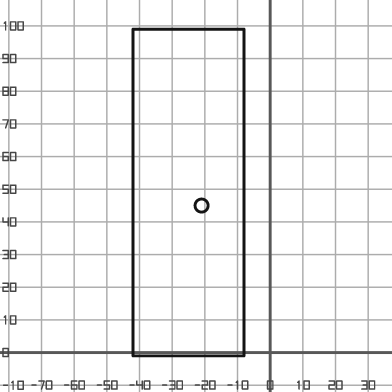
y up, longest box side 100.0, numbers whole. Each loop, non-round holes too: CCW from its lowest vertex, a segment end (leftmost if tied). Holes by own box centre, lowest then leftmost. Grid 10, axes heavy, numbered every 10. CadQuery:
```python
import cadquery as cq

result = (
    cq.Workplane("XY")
    .moveTo(-42.0, -1.0)
    .lineTo(-8.0, -1.0)
    .lineTo(-8.0, 99.0)
    .lineTo(-42.0, 99.0)
    .close()
    .moveTo(-21.0, 45.0)
    .circle(2.0)
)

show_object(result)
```